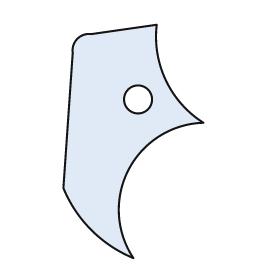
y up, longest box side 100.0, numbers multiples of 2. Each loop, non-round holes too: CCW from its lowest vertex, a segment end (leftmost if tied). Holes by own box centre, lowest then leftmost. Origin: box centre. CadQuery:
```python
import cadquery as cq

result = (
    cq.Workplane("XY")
    .moveTo(0.0, -50.0)
    .threePointArc((-2.0, -12.0), (30.0, 8.0))
    .threePointArc((14.0, 26.0), (10.0, 50.0))
    .lineTo(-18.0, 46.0)
    .threePointArc((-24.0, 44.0), (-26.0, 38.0))
    .lineTo(-30.0, -20.0)
    .threePointArc((-18.0, -38.0), (0.0, -50.0))
    .close()
    .moveTo(2.0, 18.0)
    .circle(6.0)
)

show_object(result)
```